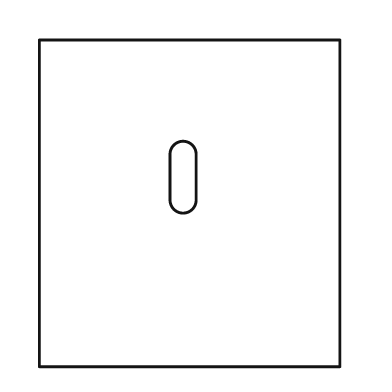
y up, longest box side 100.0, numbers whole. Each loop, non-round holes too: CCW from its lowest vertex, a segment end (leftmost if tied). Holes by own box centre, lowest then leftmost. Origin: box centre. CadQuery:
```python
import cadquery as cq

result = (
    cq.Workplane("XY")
    .moveTo(-46.0, -50.0)
    .lineTo(46.0, -50.0)
    .lineTo(46.0, 50.0)
    .lineTo(-46.0, 50.0)
    .close()
    .moveTo(-6.0, 1.0)
    .threePointArc((-2.0, -3.0), (2.0, 1.0))
    .lineTo(2.0, 15.0)
    .threePointArc((-2.0, 19.0), (-6.0, 15.0))
    .close()
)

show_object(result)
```